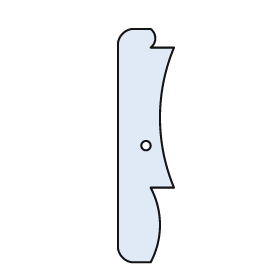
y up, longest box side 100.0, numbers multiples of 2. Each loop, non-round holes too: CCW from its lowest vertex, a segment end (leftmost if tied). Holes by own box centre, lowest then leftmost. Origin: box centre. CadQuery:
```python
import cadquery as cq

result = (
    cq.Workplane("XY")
    .moveTo(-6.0, -50.0)
    .lineTo(2.0, -50.0)
    .threePointArc((6.0, -34.0), (2.0, -18.0))
    .lineTo(12.0, -18.0)
    .threePointArc((6.0, 12.0), (12.0, 42.0))
    .lineTo(2.0, 42.0)
    .threePointArc((4.0, 46.0), (2.0, 50.0))
    .lineTo(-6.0, 50.0)
    .threePointArc((-10.0, 48.0), (-12.0, 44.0))
    .lineTo(-12.0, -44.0)
    .threePointArc((-10.0, -48.0), (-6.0, -50.0))
    .close()
    .moveTo(0.0, 0.0)
    .circle(2.0)
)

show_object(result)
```